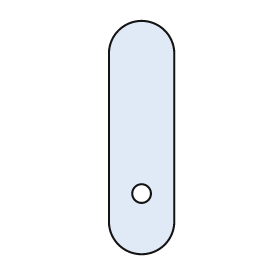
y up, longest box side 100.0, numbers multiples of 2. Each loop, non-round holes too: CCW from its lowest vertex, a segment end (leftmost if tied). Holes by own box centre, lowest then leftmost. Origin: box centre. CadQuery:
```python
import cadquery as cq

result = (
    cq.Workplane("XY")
    .moveTo(-14.0, -36.0)
    .threePointArc((0.0, -50.0), (14.0, -36.0))
    .lineTo(14.0, 36.0)
    .threePointArc((0.0, 50.0), (-14.0, 36.0))
    .close()
    .moveTo(0.0, -24.0)
    .circle(4.0)
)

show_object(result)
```